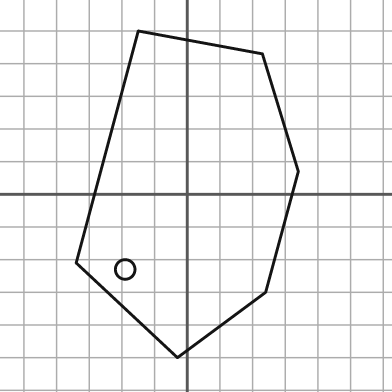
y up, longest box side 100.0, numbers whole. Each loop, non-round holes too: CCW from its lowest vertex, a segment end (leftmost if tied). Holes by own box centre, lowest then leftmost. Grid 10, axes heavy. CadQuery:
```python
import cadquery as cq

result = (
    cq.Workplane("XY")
    .moveTo(-3.0, -50.0)
    .lineTo(24.0, -30.0)
    .lineTo(34.0, 7.0)
    .lineTo(23.0, 43.0)
    .lineTo(-15.0, 50.0)
    .lineTo(-34.0, -21.0)
    .close()
    .moveTo(-19.0, -23.0)
    .circle(3.0)
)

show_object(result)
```